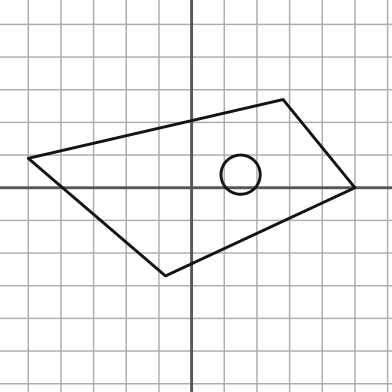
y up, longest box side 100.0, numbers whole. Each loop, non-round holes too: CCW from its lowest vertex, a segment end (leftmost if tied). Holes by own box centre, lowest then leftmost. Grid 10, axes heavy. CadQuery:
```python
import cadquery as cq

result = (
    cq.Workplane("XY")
    .moveTo(-8.0, -27.0)
    .lineTo(50.0, 0.0)
    .lineTo(28.0, 27.0)
    .lineTo(-50.0, 9.0)
    .close()
    .moveTo(15.0, 4.0)
    .circle(6.0)
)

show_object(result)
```